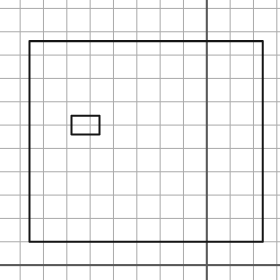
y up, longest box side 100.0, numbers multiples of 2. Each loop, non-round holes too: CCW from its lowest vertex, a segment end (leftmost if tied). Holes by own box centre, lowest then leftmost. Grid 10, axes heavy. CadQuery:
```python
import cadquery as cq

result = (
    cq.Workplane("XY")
    .moveTo(-76.0, 10.0)
    .lineTo(24.0, 10.0)
    .lineTo(24.0, 96.0)
    .lineTo(-76.0, 96.0)
    .close()
    .moveTo(-58.0, 56.0)
    .lineTo(-46.0, 56.0)
    .lineTo(-46.0, 64.0)
    .lineTo(-58.0, 64.0)
    .close()
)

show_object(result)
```